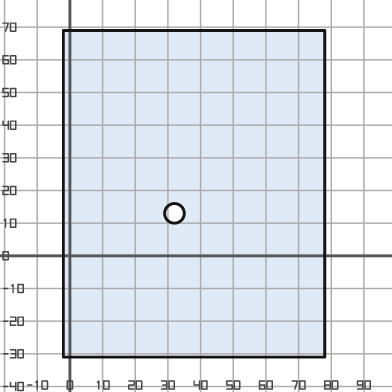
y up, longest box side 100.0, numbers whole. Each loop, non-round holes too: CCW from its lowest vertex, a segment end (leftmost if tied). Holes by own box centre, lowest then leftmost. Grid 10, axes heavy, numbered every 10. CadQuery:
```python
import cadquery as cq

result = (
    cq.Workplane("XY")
    .moveTo(-2.0, -31.0)
    .lineTo(78.0, -31.0)
    .lineTo(78.0, 69.0)
    .lineTo(-2.0, 69.0)
    .close()
    .moveTo(32.0, 13.0)
    .circle(3.0)
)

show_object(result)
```